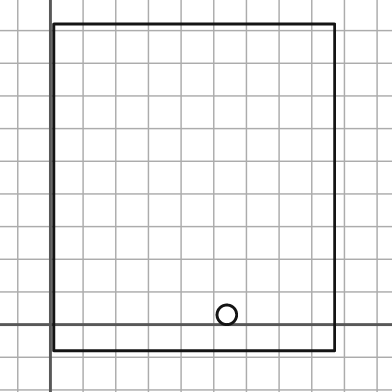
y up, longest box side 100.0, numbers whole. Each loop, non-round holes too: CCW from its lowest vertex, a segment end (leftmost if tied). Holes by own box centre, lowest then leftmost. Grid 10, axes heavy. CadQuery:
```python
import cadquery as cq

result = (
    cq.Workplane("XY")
    .moveTo(1.0, -8.0)
    .lineTo(87.0, -8.0)
    .lineTo(87.0, 92.0)
    .lineTo(1.0, 92.0)
    .close()
    .moveTo(54.0, 3.0)
    .circle(3.0)
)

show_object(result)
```